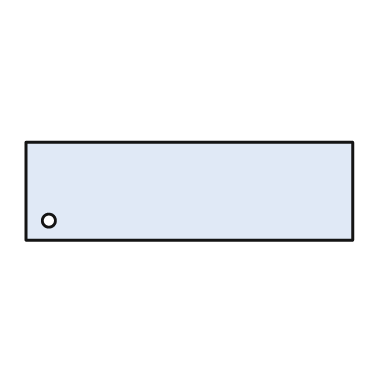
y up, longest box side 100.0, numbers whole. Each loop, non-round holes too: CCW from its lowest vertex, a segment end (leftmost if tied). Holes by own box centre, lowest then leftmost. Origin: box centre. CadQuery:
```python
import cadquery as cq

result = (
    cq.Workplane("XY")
    .moveTo(-50.0, -15.0)
    .lineTo(50.0, -15.0)
    .lineTo(50.0, 15.0)
    .lineTo(-50.0, 15.0)
    .close()
    .moveTo(-43.0, -9.0)
    .circle(2.0)
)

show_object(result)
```